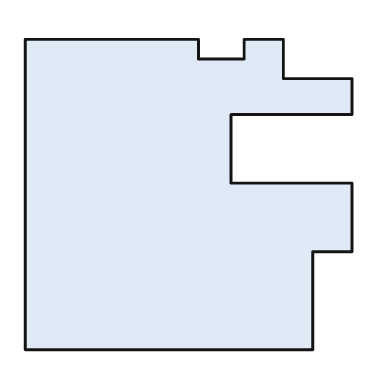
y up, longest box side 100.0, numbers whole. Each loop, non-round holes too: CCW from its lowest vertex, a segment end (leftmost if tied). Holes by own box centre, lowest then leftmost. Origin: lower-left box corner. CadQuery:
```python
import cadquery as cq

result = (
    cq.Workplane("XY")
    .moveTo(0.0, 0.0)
    .lineTo(88.0, 0.0)
    .lineTo(88.0, 30.0)
    .lineTo(100.0, 30.0)
    .lineTo(100.0, 51.0)
    .lineTo(63.0, 51.0)
    .lineTo(63.0, 72.0)
    .lineTo(100.0, 72.0)
    .lineTo(100.0, 83.0)
    .lineTo(79.0, 83.0)
    .lineTo(79.0, 95.0)
    .lineTo(67.0, 95.0)
    .lineTo(67.0, 89.0)
    .lineTo(53.0, 89.0)
    .lineTo(53.0, 95.0)
    .lineTo(0.0, 95.0)
    .close()
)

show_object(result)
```